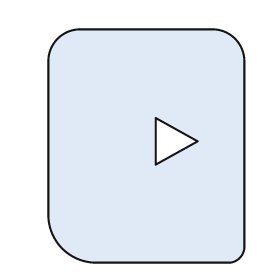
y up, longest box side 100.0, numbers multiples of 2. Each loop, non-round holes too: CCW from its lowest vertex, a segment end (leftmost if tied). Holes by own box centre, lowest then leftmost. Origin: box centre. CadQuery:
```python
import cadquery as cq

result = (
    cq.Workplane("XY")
    .moveTo(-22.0, -50.0)
    .lineTo(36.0, -50.0)
    .threePointArc((40.0, -48.0), (42.0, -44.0))
    .lineTo(42.0, 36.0)
    .threePointArc((38.0, 46.0), (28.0, 50.0))
    .lineTo(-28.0, 50.0)
    .threePointArc((-38.0, 46.0), (-42.0, 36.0))
    .lineTo(-42.0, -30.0)
    .threePointArc((-36.0, -44.0), (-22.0, -50.0))
    .close()
    .moveTo(4.0, -8.0)
    .lineTo(22.0, 2.0)
    .lineTo(4.0, 12.0)
    .close()
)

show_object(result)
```